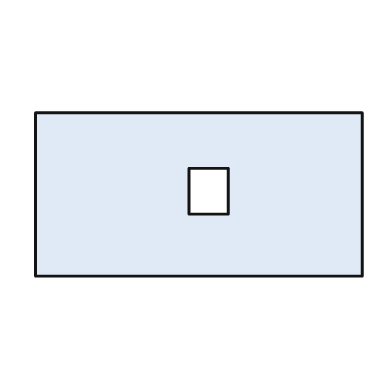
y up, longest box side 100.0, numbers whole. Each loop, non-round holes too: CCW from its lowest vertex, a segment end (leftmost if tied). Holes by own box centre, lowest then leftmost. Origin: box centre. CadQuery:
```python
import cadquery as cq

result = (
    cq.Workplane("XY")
    .moveTo(-50.0, -25.0)
    .lineTo(50.0, -25.0)
    .lineTo(50.0, 25.0)
    .lineTo(-50.0, 25.0)
    .close()
    .moveTo(-3.0, -6.0)
    .lineTo(9.0, -6.0)
    .lineTo(9.0, 8.0)
    .lineTo(-3.0, 8.0)
    .close()
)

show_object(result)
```